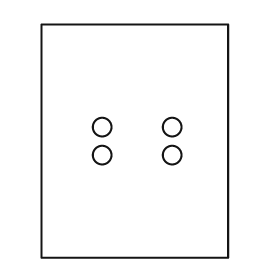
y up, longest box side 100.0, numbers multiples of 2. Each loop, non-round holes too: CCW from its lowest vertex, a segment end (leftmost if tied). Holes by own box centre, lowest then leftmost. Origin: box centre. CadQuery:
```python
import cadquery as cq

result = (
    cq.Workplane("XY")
    .moveTo(-40.0, -50.0)
    .lineTo(40.0, -50.0)
    .lineTo(40.0, 50.0)
    .lineTo(-40.0, 50.0)
    .close()
    .moveTo(-14.0, -6.0)
    .circle(4.0)
    .moveTo(16.0, -6.0)
    .circle(4.0)
    .moveTo(-14.0, 6.0)
    .circle(4.0)
    .moveTo(16.0, 6.0)
    .circle(4.0)
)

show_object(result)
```